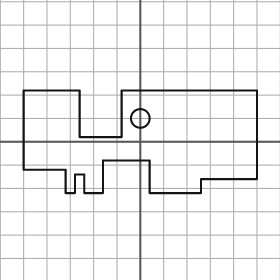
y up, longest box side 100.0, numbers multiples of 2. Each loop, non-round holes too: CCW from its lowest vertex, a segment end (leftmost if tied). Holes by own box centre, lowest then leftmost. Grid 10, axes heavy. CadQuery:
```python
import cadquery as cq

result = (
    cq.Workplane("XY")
    .moveTo(-32.0, -22.0)
    .lineTo(-28.0, -22.0)
    .lineTo(-28.0, -14.0)
    .lineTo(-24.0, -14.0)
    .lineTo(-24.0, -22.0)
    .lineTo(-16.0, -22.0)
    .lineTo(-16.0, -8.0)
    .lineTo(4.0, -8.0)
    .lineTo(4.0, -22.0)
    .lineTo(26.0, -22.0)
    .lineTo(26.0, -16.0)
    .lineTo(50.0, -16.0)
    .lineTo(50.0, 22.0)
    .lineTo(-8.0, 22.0)
    .lineTo(-8.0, 2.0)
    .lineTo(-26.0, 2.0)
    .lineTo(-26.0, 22.0)
    .lineTo(-50.0, 22.0)
    .lineTo(-50.0, -12.0)
    .lineTo(-32.0, -12.0)
    .close()
    .moveTo(0.0, 10.0)
    .circle(4.0)
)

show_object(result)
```